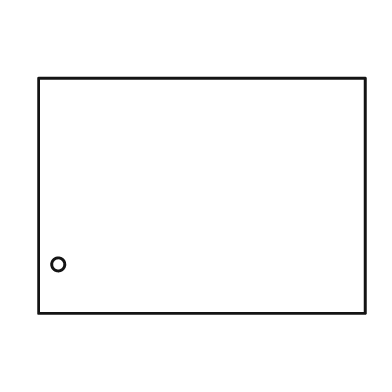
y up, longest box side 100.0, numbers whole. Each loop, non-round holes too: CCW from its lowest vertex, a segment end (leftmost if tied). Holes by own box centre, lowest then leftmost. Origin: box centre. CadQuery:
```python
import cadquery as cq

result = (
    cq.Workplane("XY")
    .moveTo(-50.0, -36.0)
    .lineTo(50.0, -36.0)
    .lineTo(50.0, 36.0)
    .lineTo(-50.0, 36.0)
    .close()
    .moveTo(-44.0, -21.0)
    .circle(2.0)
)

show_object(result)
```